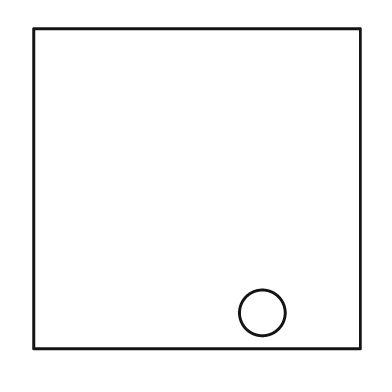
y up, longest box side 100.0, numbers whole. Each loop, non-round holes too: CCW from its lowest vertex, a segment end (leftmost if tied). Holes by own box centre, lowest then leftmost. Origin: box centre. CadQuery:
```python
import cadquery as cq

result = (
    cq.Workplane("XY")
    .moveTo(-50.0, -49.0)
    .lineTo(50.0, -49.0)
    .lineTo(50.0, 49.0)
    .lineTo(-50.0, 49.0)
    .close()
    .moveTo(20.0, -38.0)
    .circle(7.0)
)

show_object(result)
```